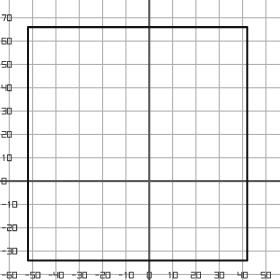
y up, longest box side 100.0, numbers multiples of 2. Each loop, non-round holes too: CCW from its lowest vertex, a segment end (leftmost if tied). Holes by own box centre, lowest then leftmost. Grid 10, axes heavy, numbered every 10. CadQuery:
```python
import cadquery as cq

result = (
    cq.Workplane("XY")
    .moveTo(-52.0, -34.0)
    .lineTo(42.0, -34.0)
    .lineTo(42.0, 66.0)
    .lineTo(-52.0, 66.0)
    .close()
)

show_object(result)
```